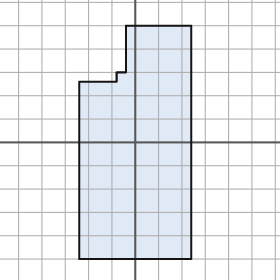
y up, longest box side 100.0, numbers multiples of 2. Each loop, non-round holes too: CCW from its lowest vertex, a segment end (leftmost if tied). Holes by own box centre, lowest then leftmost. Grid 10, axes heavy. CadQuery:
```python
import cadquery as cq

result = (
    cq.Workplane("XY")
    .moveTo(-24.0, -50.0)
    .lineTo(24.0, -50.0)
    .lineTo(24.0, 50.0)
    .lineTo(-4.0, 50.0)
    .lineTo(-4.0, 30.0)
    .lineTo(-8.0, 30.0)
    .lineTo(-8.0, 26.0)
    .lineTo(-24.0, 26.0)
    .close()
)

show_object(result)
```